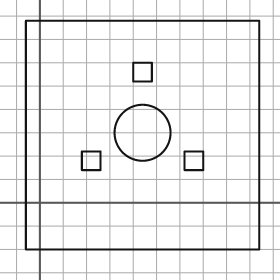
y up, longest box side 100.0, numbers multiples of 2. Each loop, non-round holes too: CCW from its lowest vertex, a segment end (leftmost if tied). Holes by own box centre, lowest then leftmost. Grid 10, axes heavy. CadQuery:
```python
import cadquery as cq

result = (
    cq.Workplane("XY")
    .moveTo(-6.0, -20.0)
    .lineTo(94.0, -20.0)
    .lineTo(94.0, 78.0)
    .lineTo(-6.0, 78.0)
    .close()
    .moveTo(18.0, 14.0)
    .lineTo(26.0, 14.0)
    .lineTo(26.0, 22.0)
    .lineTo(18.0, 22.0)
    .close()
    .moveTo(62.0, 14.0)
    .lineTo(70.0, 14.0)
    .lineTo(70.0, 22.0)
    .lineTo(62.0, 22.0)
    .close()
    .moveTo(44.0, 30.0)
    .circle(12.0)
    .moveTo(40.0, 52.0)
    .lineTo(48.0, 52.0)
    .lineTo(48.0, 60.0)
    .lineTo(40.0, 60.0)
    .close()
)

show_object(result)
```